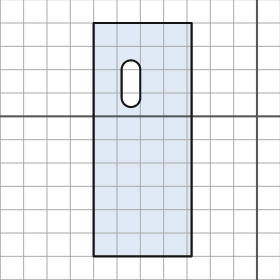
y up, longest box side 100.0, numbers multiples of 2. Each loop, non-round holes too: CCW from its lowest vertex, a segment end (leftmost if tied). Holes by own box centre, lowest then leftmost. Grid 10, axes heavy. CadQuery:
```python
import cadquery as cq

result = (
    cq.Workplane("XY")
    .moveTo(-70.0, -60.0)
    .lineTo(-28.0, -60.0)
    .lineTo(-28.0, 40.0)
    .lineTo(-70.0, 40.0)
    .close()
    .moveTo(-58.0, 8.0)
    .threePointArc((-54.0, 4.0), (-50.0, 8.0))
    .lineTo(-50.0, 20.0)
    .threePointArc((-54.0, 24.0), (-58.0, 20.0))
    .close()
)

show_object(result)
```